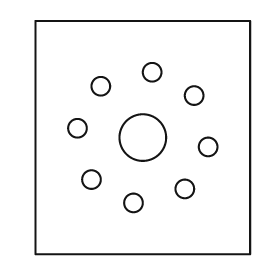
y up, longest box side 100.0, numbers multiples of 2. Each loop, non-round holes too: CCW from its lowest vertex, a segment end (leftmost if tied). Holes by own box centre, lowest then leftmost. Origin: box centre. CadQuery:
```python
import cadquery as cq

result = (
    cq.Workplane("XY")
    .moveTo(-46.0, -50.0)
    .lineTo(46.0, -50.0)
    .lineTo(46.0, 50.0)
    .lineTo(-46.0, 50.0)
    .close()
    .moveTo(-4.0, -28.0)
    .circle(4.0)
    .moveTo(18.0, -22.0)
    .circle(4.0)
    .moveTo(-22.0, -18.0)
    .circle(4.0)
    .moveTo(28.0, -4.0)
    .circle(4.0)
    .moveTo(0.0, 0.0)
    .circle(10.0)
    .moveTo(-28.0, 4.0)
    .circle(4.0)
    .moveTo(22.0, 18.0)
    .circle(4.0)
    .moveTo(-18.0, 22.0)
    .circle(4.0)
    .moveTo(4.0, 28.0)
    .circle(4.0)
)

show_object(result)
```